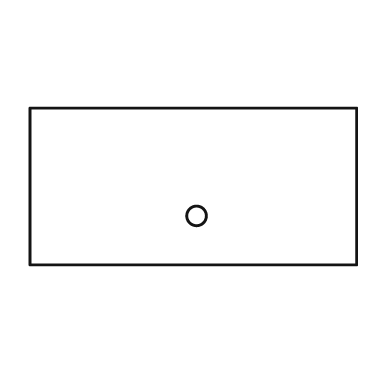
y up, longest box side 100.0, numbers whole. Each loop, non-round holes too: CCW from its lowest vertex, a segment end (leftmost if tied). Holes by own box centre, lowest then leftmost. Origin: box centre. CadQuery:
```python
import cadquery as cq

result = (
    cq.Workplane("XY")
    .moveTo(-50.0, -24.0)
    .lineTo(50.0, -24.0)
    .lineTo(50.0, 24.0)
    .lineTo(-50.0, 24.0)
    .close()
    .moveTo(1.0, -9.0)
    .circle(3.0)
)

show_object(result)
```